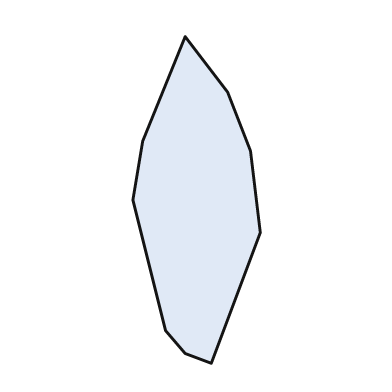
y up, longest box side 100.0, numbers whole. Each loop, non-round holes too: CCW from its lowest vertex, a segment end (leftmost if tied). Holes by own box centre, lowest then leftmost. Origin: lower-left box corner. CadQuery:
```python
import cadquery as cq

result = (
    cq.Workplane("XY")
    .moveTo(24.0, 0.0)
    .lineTo(39.0, 40.0)
    .lineTo(36.0, 65.0)
    .lineTo(29.0, 83.0)
    .lineTo(16.0, 100.0)
    .lineTo(3.0, 68.0)
    .lineTo(0.0, 50.0)
    .lineTo(10.0, 10.0)
    .lineTo(16.0, 3.0)
    .close()
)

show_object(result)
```